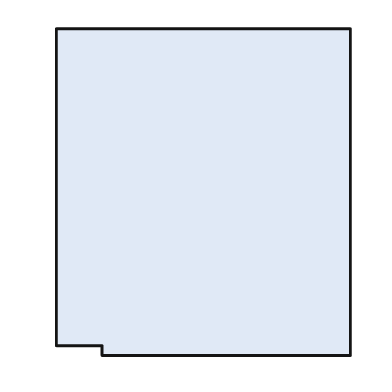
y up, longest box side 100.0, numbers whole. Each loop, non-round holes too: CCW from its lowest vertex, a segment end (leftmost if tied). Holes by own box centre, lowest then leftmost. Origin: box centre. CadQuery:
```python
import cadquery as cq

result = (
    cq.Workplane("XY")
    .moveTo(-31.0, -50.0)
    .lineTo(45.0, -50.0)
    .lineTo(45.0, 50.0)
    .lineTo(-45.0, 50.0)
    .lineTo(-45.0, -47.0)
    .lineTo(-31.0, -47.0)
    .close()
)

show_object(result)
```